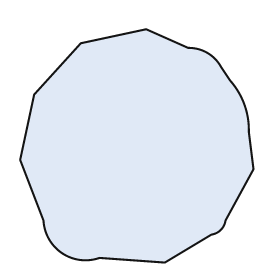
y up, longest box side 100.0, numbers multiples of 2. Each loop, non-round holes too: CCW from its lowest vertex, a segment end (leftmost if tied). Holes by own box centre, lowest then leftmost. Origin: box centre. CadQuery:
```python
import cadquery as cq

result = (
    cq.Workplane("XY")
    .moveTo(12.0, -50.0)
    .lineTo(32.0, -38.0)
    .threePointArc((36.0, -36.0), (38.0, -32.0))
    .lineTo(50.0, -10.0)
    .lineTo(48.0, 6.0)
    .threePointArc((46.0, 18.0), (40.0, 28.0))
    .lineTo(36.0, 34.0)
    .threePointArc((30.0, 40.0), (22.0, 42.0))
    .lineTo(4.0, 50.0)
    .lineTo(-24.0, 44.0)
    .lineTo(-44.0, 22.0)
    .lineTo(-50.0, -6.0)
    .lineTo(-40.0, -32.0)
    .threePointArc((-32.0, -46.0), (-16.0, -48.0))
    .close()
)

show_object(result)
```